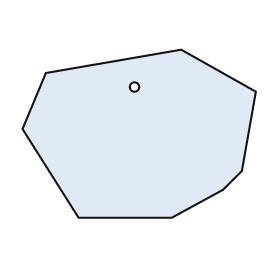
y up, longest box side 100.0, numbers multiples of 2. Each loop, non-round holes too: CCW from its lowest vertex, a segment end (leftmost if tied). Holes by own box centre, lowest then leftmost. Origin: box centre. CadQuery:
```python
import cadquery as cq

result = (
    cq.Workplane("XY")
    .moveTo(-26.0, -36.0)
    .lineTo(14.0, -36.0)
    .lineTo(36.0, -24.0)
    .lineTo(44.0, -16.0)
    .lineTo(50.0, 18.0)
    .lineTo(18.0, 36.0)
    .lineTo(-40.0, 26.0)
    .lineTo(-50.0, 2.0)
    .close()
    .moveTo(-2.0, 20.0)
    .circle(2.0)
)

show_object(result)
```